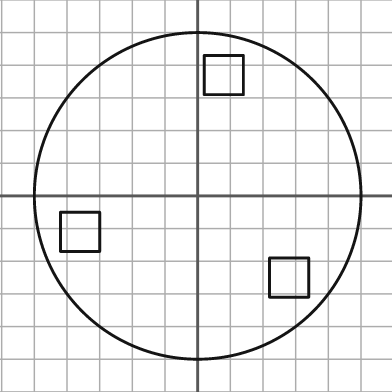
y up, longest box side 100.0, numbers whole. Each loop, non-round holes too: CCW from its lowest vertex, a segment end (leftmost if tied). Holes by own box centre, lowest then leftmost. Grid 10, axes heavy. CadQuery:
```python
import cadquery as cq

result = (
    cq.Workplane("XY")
    .moveTo(0.0, 0.0)
    .circle(50.0)
    .moveTo(22.0, -31.0)
    .lineTo(34.0, -31.0)
    .lineTo(34.0, -19.0)
    .lineTo(22.0, -19.0)
    .close()
    .moveTo(-42.0, -17.0)
    .lineTo(-30.0, -17.0)
    .lineTo(-30.0, -5.0)
    .lineTo(-42.0, -5.0)
    .close()
    .moveTo(2.0, 31.0)
    .lineTo(14.0, 31.0)
    .lineTo(14.0, 43.0)
    .lineTo(2.0, 43.0)
    .close()
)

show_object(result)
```